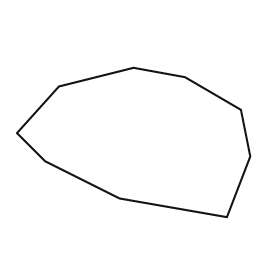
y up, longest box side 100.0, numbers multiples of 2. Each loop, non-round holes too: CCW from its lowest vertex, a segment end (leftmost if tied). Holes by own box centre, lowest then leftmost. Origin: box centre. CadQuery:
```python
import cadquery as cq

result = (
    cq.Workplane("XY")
    .moveTo(40.0, -32.0)
    .lineTo(50.0, -6.0)
    .lineTo(46.0, 14.0)
    .lineTo(22.0, 28.0)
    .lineTo(0.0, 32.0)
    .lineTo(-32.0, 24.0)
    .lineTo(-50.0, 4.0)
    .lineTo(-38.0, -8.0)
    .lineTo(-6.0, -24.0)
    .close()
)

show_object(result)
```